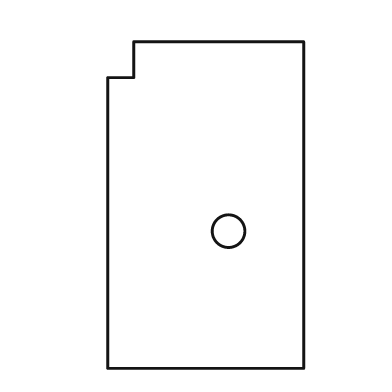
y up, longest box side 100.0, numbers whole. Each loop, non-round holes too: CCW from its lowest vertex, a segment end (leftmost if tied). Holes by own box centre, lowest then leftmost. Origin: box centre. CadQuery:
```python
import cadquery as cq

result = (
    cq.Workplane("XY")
    .moveTo(-30.0, -50.0)
    .lineTo(30.0, -50.0)
    .lineTo(30.0, 50.0)
    .lineTo(-22.0, 50.0)
    .lineTo(-22.0, 39.0)
    .lineTo(-30.0, 39.0)
    .close()
    .moveTo(7.0, -8.0)
    .circle(5.0)
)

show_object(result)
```